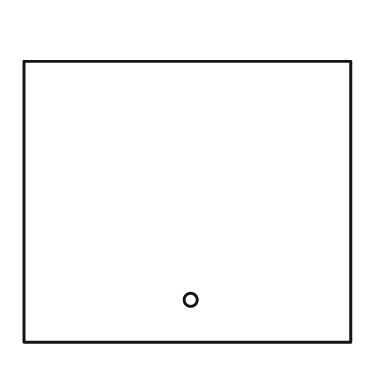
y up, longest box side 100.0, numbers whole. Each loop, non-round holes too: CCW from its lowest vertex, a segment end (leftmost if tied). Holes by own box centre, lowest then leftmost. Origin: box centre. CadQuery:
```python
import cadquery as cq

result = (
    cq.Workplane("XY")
    .moveTo(-50.0, -43.0)
    .lineTo(50.0, -43.0)
    .lineTo(50.0, 43.0)
    .lineTo(-50.0, 43.0)
    .close()
    .moveTo(1.0, -30.0)
    .circle(2.0)
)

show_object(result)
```